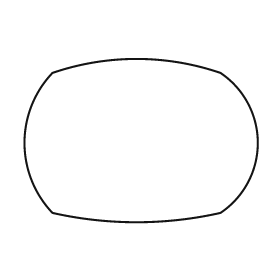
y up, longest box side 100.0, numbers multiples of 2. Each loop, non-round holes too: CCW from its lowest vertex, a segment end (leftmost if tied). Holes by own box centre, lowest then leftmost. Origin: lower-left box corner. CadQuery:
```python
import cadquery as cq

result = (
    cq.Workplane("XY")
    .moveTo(12.0, 4.0)
    .threePointArc((48.0, 0.0), (84.0, 4.0))
    .threePointArc((100.0, 34.0), (84.0, 64.0))
    .threePointArc((48.0, 70.0), (12.0, 64.0))
    .threePointArc((0.0, 34.0), (12.0, 4.0))
    .close()
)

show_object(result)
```